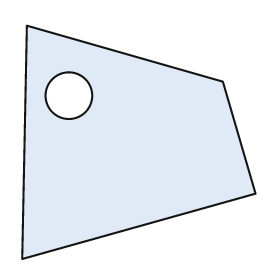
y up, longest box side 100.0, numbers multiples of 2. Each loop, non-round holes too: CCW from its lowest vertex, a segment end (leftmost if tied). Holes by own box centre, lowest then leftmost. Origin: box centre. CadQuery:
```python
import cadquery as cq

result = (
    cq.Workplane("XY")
    .moveTo(-50.0, -50.0)
    .lineTo(50.0, -22.0)
    .lineTo(36.0, 26.0)
    .lineTo(-48.0, 50.0)
    .close()
    .moveTo(-30.0, 20.0)
    .circle(10.0)
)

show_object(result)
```